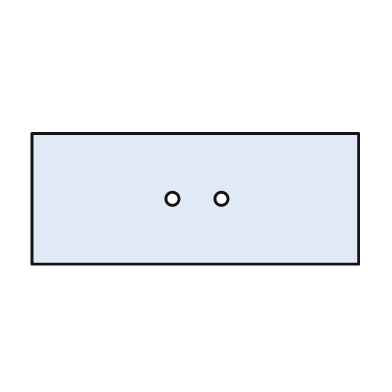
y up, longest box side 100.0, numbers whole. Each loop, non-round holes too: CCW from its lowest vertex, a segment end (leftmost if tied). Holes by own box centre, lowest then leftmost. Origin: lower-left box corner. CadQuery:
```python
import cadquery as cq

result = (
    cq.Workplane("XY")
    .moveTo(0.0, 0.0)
    .lineTo(100.0, 0.0)
    .lineTo(100.0, 40.0)
    .lineTo(0.0, 40.0)
    .close()
    .moveTo(43.0, 20.0)
    .circle(2.0)
    .moveTo(58.0, 20.0)
    .circle(2.0)
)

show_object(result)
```